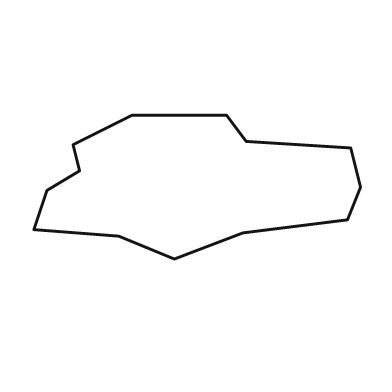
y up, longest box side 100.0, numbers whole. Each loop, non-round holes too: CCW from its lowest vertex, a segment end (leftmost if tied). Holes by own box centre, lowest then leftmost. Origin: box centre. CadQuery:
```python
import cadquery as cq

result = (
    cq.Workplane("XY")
    .moveTo(-7.0, -22.0)
    .lineTo(14.0, -14.0)
    .lineTo(46.0, -10.0)
    .lineTo(50.0, 0.0)
    .lineTo(47.0, 12.0)
    .lineTo(15.0, 14.0)
    .lineTo(9.0, 22.0)
    .lineTo(-20.0, 22.0)
    .lineTo(-38.0, 13.0)
    .lineTo(-36.0, 5.0)
    .lineTo(-46.0, -1.0)
    .lineTo(-50.0, -13.0)
    .lineTo(-24.0, -15.0)
    .close()
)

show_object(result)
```